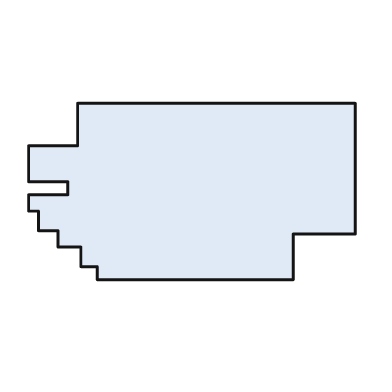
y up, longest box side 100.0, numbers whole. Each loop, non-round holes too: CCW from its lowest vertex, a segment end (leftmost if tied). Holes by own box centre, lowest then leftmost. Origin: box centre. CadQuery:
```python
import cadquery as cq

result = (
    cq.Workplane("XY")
    .moveTo(-29.0, -27.0)
    .lineTo(31.0, -27.0)
    .lineTo(31.0, -13.0)
    .lineTo(50.0, -13.0)
    .lineTo(50.0, 27.0)
    .lineTo(-35.0, 27.0)
    .lineTo(-35.0, 14.0)
    .lineTo(-50.0, 14.0)
    .lineTo(-50.0, 3.0)
    .lineTo(-38.0, 3.0)
    .lineTo(-38.0, -1.0)
    .lineTo(-50.0, -1.0)
    .lineTo(-50.0, -6.0)
    .lineTo(-47.0, -6.0)
    .lineTo(-47.0, -12.0)
    .lineTo(-41.0, -12.0)
    .lineTo(-41.0, -17.0)
    .lineTo(-34.0, -17.0)
    .lineTo(-34.0, -23.0)
    .lineTo(-29.0, -23.0)
    .close()
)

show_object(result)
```